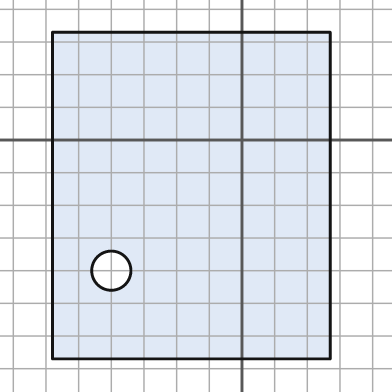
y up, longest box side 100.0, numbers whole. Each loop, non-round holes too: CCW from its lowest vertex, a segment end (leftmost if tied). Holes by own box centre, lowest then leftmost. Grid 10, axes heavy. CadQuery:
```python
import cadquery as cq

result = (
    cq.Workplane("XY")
    .moveTo(-58.0, -67.0)
    .lineTo(27.0, -67.0)
    .lineTo(27.0, 33.0)
    .lineTo(-58.0, 33.0)
    .close()
    .moveTo(-40.0, -40.0)
    .circle(6.0)
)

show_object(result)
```